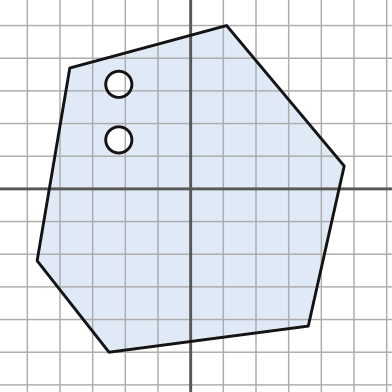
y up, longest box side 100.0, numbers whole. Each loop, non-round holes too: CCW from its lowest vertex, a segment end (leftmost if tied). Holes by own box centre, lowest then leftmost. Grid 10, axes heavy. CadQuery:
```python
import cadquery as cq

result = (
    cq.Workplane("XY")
    .moveTo(-25.0, -50.0)
    .lineTo(36.0, -42.0)
    .lineTo(47.0, 7.0)
    .lineTo(11.0, 50.0)
    .lineTo(-37.0, 37.0)
    .lineTo(-47.0, -22.0)
    .close()
    .moveTo(-22.0, 15.0)
    .circle(4.0)
    .moveTo(-22.0, 32.0)
    .circle(4.0)
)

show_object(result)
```